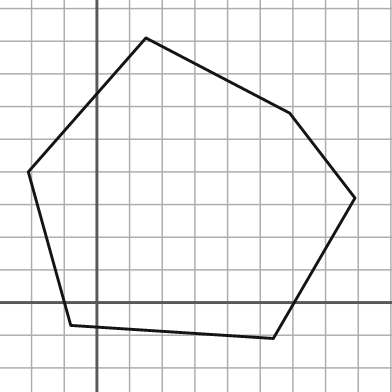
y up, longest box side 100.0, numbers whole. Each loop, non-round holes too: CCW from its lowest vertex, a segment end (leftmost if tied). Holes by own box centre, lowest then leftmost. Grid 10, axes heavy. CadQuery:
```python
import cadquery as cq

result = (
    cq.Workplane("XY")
    .moveTo(54.0, -11.0)
    .lineTo(79.0, 32.0)
    .lineTo(59.0, 58.0)
    .lineTo(15.0, 81.0)
    .lineTo(-21.0, 40.0)
    .lineTo(-8.0, -7.0)
    .close()
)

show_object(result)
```